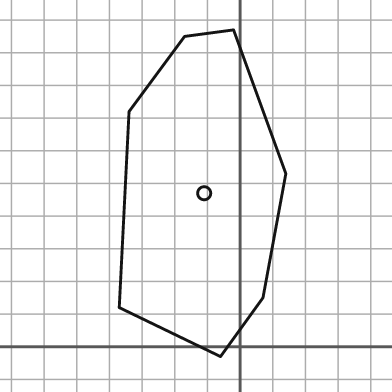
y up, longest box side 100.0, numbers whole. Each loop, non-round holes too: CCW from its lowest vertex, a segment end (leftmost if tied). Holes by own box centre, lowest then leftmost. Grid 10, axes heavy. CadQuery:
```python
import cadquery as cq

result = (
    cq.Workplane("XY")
    .moveTo(-6.0, -3.0)
    .lineTo(7.0, 15.0)
    .lineTo(14.0, 53.0)
    .lineTo(-2.0, 97.0)
    .lineTo(-17.0, 95.0)
    .lineTo(-34.0, 72.0)
    .lineTo(-37.0, 12.0)
    .close()
    .moveTo(-11.0, 47.0)
    .circle(2.0)
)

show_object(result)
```